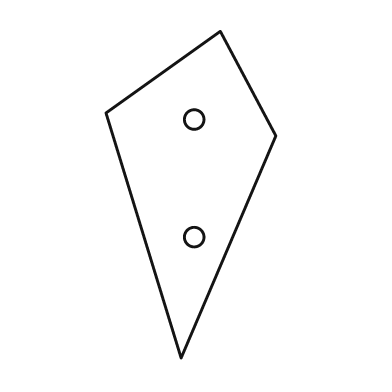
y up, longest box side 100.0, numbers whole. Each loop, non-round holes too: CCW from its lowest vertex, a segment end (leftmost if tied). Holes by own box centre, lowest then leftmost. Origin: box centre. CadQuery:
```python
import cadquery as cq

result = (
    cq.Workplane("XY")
    .moveTo(-3.0, -50.0)
    .lineTo(26.0, 18.0)
    .lineTo(9.0, 50.0)
    .lineTo(-26.0, 25.0)
    .close()
    .moveTo(1.0, -13.0)
    .circle(3.0)
    .moveTo(1.0, 23.0)
    .circle(3.0)
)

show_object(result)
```